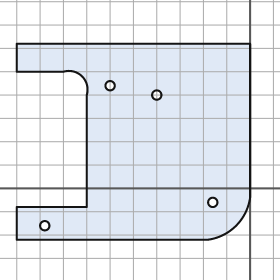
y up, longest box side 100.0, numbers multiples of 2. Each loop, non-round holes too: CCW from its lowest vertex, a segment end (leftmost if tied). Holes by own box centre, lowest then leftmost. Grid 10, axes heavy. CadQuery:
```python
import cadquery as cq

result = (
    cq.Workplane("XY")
    .moveTo(-100.0, -22.0)
    .lineTo(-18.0, -22.0)
    .threePointArc((-6.0, -16.0), (0.0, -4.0))
    .lineTo(0.0, 62.0)
    .lineTo(-100.0, 62.0)
    .lineTo(-100.0, 50.0)
    .lineTo(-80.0, 50.0)
    .threePointArc((-72.0, 48.0), (-70.0, 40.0))
    .lineTo(-70.0, -8.0)
    .lineTo(-100.0, -8.0)
    .close()
    .moveTo(-88.0, -16.0)
    .circle(2.0)
    .moveTo(-16.0, -6.0)
    .circle(2.0)
    .moveTo(-40.0, 40.0)
    .circle(2.0)
    .moveTo(-60.0, 44.0)
    .circle(2.0)
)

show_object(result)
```